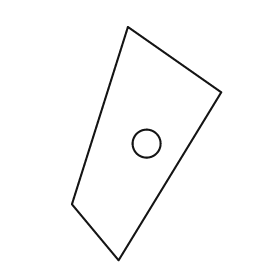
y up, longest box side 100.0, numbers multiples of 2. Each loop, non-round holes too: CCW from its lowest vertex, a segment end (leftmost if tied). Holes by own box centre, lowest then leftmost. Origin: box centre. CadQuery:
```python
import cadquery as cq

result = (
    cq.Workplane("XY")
    .moveTo(-12.0, -50.0)
    .lineTo(32.0, 22.0)
    .lineTo(-8.0, 50.0)
    .lineTo(-32.0, -26.0)
    .close()
    .moveTo(0.0, 0.0)
    .circle(6.0)
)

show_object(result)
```